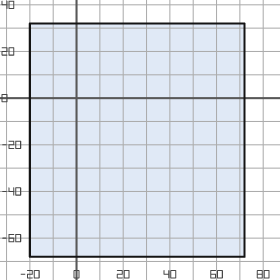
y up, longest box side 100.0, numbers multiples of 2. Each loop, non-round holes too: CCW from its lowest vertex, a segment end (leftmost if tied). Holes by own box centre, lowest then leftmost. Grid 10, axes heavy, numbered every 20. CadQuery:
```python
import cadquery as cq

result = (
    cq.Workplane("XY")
    .moveTo(-20.0, -68.0)
    .lineTo(72.0, -68.0)
    .lineTo(72.0, 32.0)
    .lineTo(-20.0, 32.0)
    .close()
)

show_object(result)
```